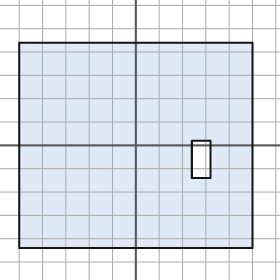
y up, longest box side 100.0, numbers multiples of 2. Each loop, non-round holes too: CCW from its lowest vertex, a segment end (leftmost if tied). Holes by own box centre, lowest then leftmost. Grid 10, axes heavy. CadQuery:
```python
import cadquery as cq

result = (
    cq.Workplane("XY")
    .moveTo(-50.0, -44.0)
    .lineTo(50.0, -44.0)
    .lineTo(50.0, 44.0)
    .lineTo(-50.0, 44.0)
    .close()
    .moveTo(24.0, -14.0)
    .lineTo(32.0, -14.0)
    .lineTo(32.0, 2.0)
    .lineTo(24.0, 2.0)
    .close()
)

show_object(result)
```